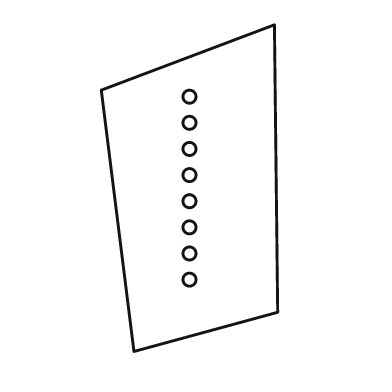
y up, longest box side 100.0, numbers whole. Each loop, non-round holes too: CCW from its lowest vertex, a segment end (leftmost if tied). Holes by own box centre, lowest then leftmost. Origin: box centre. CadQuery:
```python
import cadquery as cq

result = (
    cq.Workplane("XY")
    .moveTo(-17.0, -50.0)
    .lineTo(27.0, -38.0)
    .lineTo(26.0, 50.0)
    .lineTo(-27.0, 30.0)
    .close()
    .moveTo(0.0, -28.0)
    .circle(2.0)
    .moveTo(0.0, -20.0)
    .circle(2.0)
    .moveTo(0.0, -12.0)
    .circle(2.0)
    .moveTo(0.0, -4.0)
    .circle(2.0)
    .moveTo(0.0, 4.0)
    .circle(2.0)
    .moveTo(0.0, 12.0)
    .circle(2.0)
    .moveTo(0.0, 20.0)
    .circle(2.0)
    .moveTo(0.0, 28.0)
    .circle(2.0)
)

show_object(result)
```